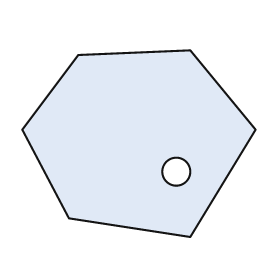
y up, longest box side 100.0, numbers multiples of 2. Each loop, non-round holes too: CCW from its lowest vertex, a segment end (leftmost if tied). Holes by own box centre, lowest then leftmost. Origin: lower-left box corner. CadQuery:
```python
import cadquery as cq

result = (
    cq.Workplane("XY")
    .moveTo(72.0, 0.0)
    .lineTo(100.0, 46.0)
    .lineTo(72.0, 80.0)
    .lineTo(24.0, 78.0)
    .lineTo(0.0, 46.0)
    .lineTo(20.0, 8.0)
    .close()
    .moveTo(66.0, 28.0)
    .circle(6.0)
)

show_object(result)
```